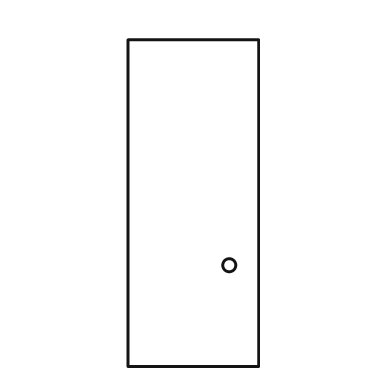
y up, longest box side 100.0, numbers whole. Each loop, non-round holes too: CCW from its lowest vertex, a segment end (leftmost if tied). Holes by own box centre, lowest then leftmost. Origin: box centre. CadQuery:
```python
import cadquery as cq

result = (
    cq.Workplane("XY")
    .moveTo(-20.0, -50.0)
    .lineTo(20.0, -50.0)
    .lineTo(20.0, 50.0)
    .lineTo(-20.0, 50.0)
    .close()
    .moveTo(11.0, -19.0)
    .circle(2.0)
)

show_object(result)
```